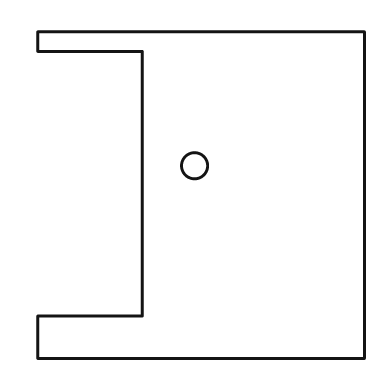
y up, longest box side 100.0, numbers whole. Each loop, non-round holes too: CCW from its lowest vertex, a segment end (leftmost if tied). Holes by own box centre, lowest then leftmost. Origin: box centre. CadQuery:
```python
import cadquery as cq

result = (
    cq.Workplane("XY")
    .moveTo(-50.0, -50.0)
    .lineTo(50.0, -50.0)
    .lineTo(50.0, 50.0)
    .lineTo(-50.0, 50.0)
    .lineTo(-50.0, 44.0)
    .lineTo(-18.0, 44.0)
    .lineTo(-18.0, -37.0)
    .lineTo(-50.0, -37.0)
    .close()
    .moveTo(-2.0, 9.0)
    .circle(4.0)
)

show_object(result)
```